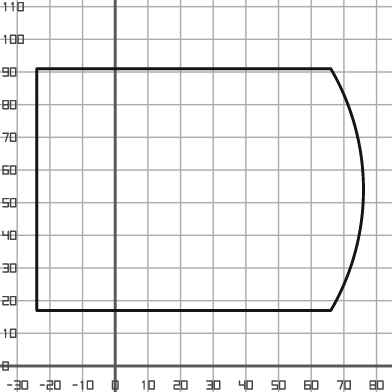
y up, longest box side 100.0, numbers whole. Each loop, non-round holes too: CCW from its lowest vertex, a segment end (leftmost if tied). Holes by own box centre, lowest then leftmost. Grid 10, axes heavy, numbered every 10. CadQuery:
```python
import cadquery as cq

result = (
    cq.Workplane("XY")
    .moveTo(-24.0, 17.0)
    .lineTo(66.0, 17.0)
    .threePointArc((76.0, 54.0), (66.0, 91.0))
    .lineTo(-24.0, 91.0)
    .close()
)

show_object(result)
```